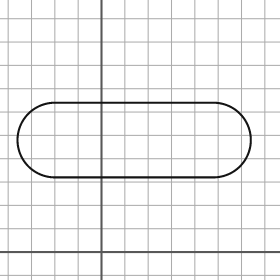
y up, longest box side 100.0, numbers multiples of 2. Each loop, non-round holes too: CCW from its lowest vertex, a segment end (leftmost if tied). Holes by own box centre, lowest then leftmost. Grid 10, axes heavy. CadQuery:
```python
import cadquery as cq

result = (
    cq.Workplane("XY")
    .moveTo(-20.0, 32.0)
    .lineTo(48.0, 32.0)
    .threePointArc((64.0, 48.0), (48.0, 64.0))
    .lineTo(-20.0, 64.0)
    .threePointArc((-36.0, 48.0), (-20.0, 32.0))
    .close()
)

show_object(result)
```